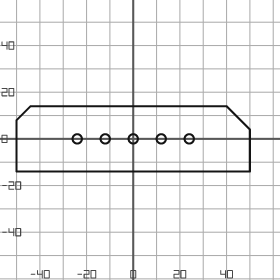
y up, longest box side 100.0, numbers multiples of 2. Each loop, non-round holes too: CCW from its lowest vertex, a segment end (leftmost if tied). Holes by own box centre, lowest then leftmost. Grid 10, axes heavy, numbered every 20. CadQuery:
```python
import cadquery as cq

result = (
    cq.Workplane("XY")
    .moveTo(-50.0, -14.0)
    .lineTo(50.0, -14.0)
    .lineTo(50.0, 4.0)
    .lineTo(40.0, 14.0)
    .lineTo(-44.0, 14.0)
    .lineTo(-50.0, 8.0)
    .close()
    .moveTo(-24.0, 0.0)
    .circle(2.0)
    .moveTo(-12.0, 0.0)
    .circle(2.0)
    .moveTo(0.0, 0.0)
    .circle(2.0)
    .moveTo(12.0, 0.0)
    .circle(2.0)
    .moveTo(24.0, 0.0)
    .circle(2.0)
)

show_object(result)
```